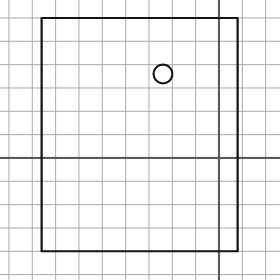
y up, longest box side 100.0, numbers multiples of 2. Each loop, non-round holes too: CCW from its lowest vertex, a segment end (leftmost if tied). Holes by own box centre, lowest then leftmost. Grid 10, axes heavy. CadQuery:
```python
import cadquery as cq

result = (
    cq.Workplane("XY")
    .moveTo(-76.0, -40.0)
    .lineTo(8.0, -40.0)
    .lineTo(8.0, 60.0)
    .lineTo(-76.0, 60.0)
    .close()
    .moveTo(-24.0, 36.0)
    .circle(4.0)
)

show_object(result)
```